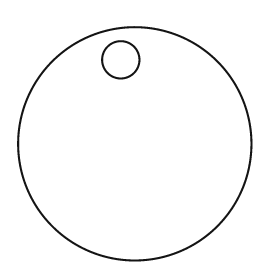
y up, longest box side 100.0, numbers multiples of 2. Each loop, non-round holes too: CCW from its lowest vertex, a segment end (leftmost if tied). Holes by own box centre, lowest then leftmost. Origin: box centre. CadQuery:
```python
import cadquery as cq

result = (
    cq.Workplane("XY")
    .moveTo(0.0, 0.0)
    .circle(50.0)
    .moveTo(-6.0, 36.0)
    .circle(8.0)
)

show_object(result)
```